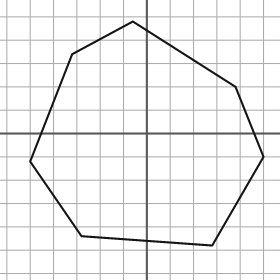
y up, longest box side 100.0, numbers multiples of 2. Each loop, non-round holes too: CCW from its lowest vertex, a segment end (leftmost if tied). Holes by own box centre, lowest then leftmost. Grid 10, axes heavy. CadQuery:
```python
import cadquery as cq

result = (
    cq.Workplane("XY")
    .moveTo(28.0, -48.0)
    .lineTo(50.0, -10.0)
    .lineTo(38.0, 20.0)
    .lineTo(-6.0, 48.0)
    .lineTo(-32.0, 34.0)
    .lineTo(-50.0, -12.0)
    .lineTo(-28.0, -44.0)
    .close()
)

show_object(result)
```